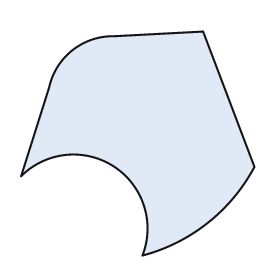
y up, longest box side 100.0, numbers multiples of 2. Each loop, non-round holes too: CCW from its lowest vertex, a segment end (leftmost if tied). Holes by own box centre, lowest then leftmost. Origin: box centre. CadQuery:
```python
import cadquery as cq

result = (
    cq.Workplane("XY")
    .moveTo(2.0, -48.0)
    .threePointArc((30.0, -34.0), (50.0, -10.0))
    .lineTo(28.0, 48.0)
    .lineTo(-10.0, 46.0)
    .threePointArc((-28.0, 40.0), (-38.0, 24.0))
    .lineTo(-50.0, -14.0)
    .threePointArc((-10.0, -10.0), (2.0, -48.0))
    .close()
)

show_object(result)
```